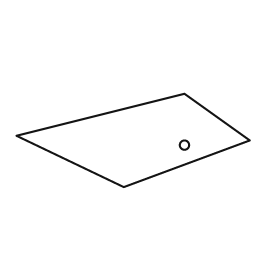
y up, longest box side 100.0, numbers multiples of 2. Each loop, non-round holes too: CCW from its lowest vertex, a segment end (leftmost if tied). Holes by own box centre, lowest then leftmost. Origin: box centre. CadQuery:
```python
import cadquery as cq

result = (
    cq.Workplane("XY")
    .moveTo(-4.0, -20.0)
    .lineTo(50.0, 0.0)
    .lineTo(22.0, 20.0)
    .lineTo(-50.0, 2.0)
    .close()
    .moveTo(22.0, -2.0)
    .circle(2.0)
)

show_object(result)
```